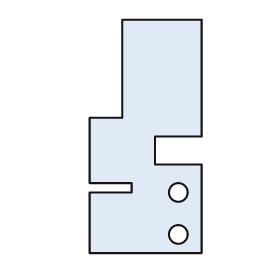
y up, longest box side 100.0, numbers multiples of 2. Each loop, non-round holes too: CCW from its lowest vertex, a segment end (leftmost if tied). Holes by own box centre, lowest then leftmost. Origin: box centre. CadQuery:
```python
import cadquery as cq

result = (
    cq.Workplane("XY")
    .moveTo(-24.0, -50.0)
    .lineTo(24.0, -50.0)
    .lineTo(24.0, -12.0)
    .lineTo(4.0, -12.0)
    .lineTo(4.0, 0.0)
    .lineTo(24.0, 0.0)
    .lineTo(24.0, 50.0)
    .lineTo(-10.0, 50.0)
    .lineTo(-10.0, 8.0)
    .lineTo(-24.0, 8.0)
    .lineTo(-24.0, -20.0)
    .lineTo(-6.0, -20.0)
    .lineTo(-6.0, -24.0)
    .lineTo(-24.0, -24.0)
    .close()
    .moveTo(14.0, -42.0)
    .circle(4.0)
    .moveTo(14.0, -24.0)
    .circle(4.0)
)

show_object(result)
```